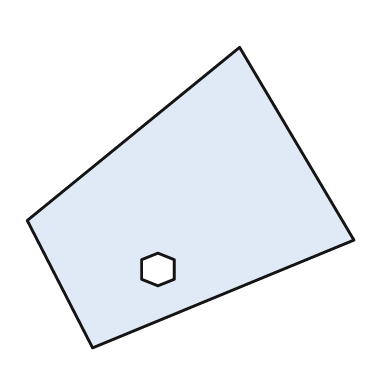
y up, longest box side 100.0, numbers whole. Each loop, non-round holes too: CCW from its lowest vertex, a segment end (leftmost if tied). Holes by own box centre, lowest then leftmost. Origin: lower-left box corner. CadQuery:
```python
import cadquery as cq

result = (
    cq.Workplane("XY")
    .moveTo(20.0, 0.0)
    .lineTo(100.0, 33.0)
    .lineTo(65.0, 92.0)
    .lineTo(0.0, 39.0)
    .close()
    .moveTo(40.0, 19.0)
    .lineTo(45.0, 21.0)
    .lineTo(45.0, 27.0)
    .lineTo(40.0, 29.0)
    .lineTo(35.0, 27.0)
    .lineTo(35.0, 21.0)
    .close()
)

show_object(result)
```